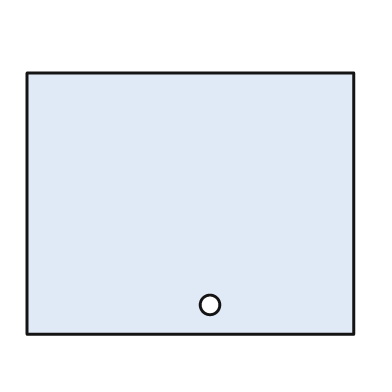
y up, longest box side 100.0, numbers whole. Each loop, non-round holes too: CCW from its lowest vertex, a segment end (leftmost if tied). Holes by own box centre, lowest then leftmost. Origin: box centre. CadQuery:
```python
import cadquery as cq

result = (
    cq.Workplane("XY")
    .moveTo(-50.0, -40.0)
    .lineTo(50.0, -40.0)
    .lineTo(50.0, 40.0)
    .lineTo(-50.0, 40.0)
    .close()
    .moveTo(6.0, -31.0)
    .circle(3.0)
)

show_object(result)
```